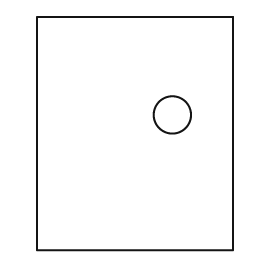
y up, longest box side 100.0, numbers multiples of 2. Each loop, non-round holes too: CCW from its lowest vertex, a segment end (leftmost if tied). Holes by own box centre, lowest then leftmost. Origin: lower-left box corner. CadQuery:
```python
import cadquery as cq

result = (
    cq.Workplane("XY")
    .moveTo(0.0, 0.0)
    .lineTo(84.0, 0.0)
    .lineTo(84.0, 100.0)
    .lineTo(0.0, 100.0)
    .close()
    .moveTo(58.0, 58.0)
    .circle(8.0)
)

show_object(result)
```